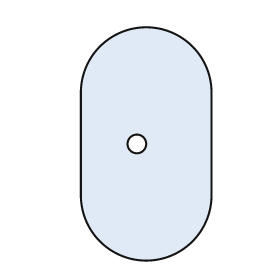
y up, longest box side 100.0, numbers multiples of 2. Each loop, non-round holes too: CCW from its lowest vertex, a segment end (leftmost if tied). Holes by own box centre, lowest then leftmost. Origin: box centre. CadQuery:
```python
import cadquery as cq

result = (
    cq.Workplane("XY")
    .moveTo(-28.0, -22.0)
    .threePointArc((0.0, -50.0), (28.0, -22.0))
    .lineTo(28.0, 22.0)
    .threePointArc((0.0, 50.0), (-28.0, 22.0))
    .close()
    .moveTo(-4.0, 0.0)
    .circle(4.0)
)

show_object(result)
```